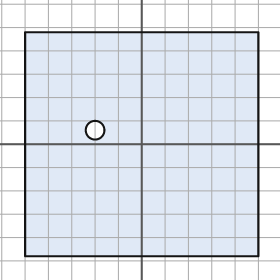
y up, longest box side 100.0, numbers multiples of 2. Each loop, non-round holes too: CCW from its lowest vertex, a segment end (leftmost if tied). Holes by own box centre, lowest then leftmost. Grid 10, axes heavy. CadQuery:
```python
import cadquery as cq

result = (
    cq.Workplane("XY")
    .moveTo(-50.0, -48.0)
    .lineTo(50.0, -48.0)
    .lineTo(50.0, 48.0)
    .lineTo(-50.0, 48.0)
    .close()
    .moveTo(-20.0, 6.0)
    .circle(4.0)
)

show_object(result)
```